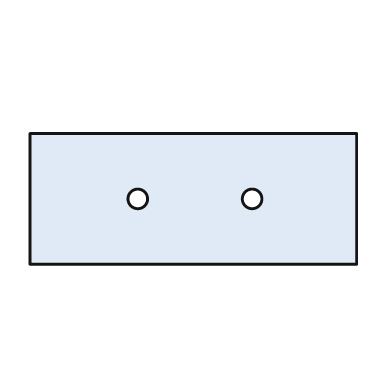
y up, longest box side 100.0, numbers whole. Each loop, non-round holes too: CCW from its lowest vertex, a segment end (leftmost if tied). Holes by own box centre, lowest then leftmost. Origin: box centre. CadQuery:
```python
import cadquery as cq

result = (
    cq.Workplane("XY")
    .moveTo(-50.0, -20.0)
    .lineTo(50.0, -20.0)
    .lineTo(50.0, 20.0)
    .lineTo(-50.0, 20.0)
    .close()
    .moveTo(-17.0, 0.0)
    .circle(3.0)
    .moveTo(18.0, 0.0)
    .circle(3.0)
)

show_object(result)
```